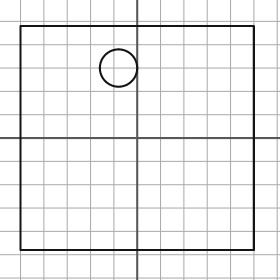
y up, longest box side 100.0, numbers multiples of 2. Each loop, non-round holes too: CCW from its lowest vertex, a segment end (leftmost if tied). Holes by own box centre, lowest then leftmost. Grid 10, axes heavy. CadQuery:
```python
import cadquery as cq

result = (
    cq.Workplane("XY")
    .moveTo(-50.0, -48.0)
    .lineTo(50.0, -48.0)
    .lineTo(50.0, 48.0)
    .lineTo(-50.0, 48.0)
    .close()
    .moveTo(-8.0, 30.0)
    .circle(8.0)
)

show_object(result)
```